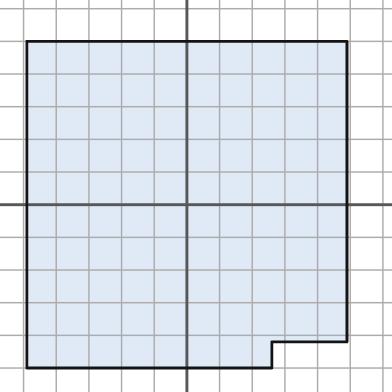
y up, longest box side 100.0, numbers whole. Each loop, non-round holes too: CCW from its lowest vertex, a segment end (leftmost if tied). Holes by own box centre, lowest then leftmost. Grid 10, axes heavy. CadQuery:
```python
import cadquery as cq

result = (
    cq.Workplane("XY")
    .moveTo(-49.0, -50.0)
    .lineTo(26.0, -50.0)
    .lineTo(26.0, -42.0)
    .lineTo(49.0, -42.0)
    .lineTo(49.0, 50.0)
    .lineTo(-49.0, 50.0)
    .close()
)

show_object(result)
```